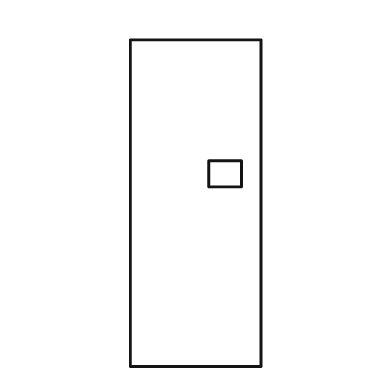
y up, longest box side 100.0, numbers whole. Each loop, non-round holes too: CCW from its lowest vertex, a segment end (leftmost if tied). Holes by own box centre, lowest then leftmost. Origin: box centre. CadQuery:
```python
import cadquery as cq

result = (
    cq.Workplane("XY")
    .moveTo(-20.0, -50.0)
    .lineTo(20.0, -50.0)
    .lineTo(20.0, 50.0)
    .lineTo(-20.0, 50.0)
    .close()
    .moveTo(4.0, 5.0)
    .lineTo(14.0, 5.0)
    .lineTo(14.0, 13.0)
    .lineTo(4.0, 13.0)
    .close()
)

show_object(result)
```